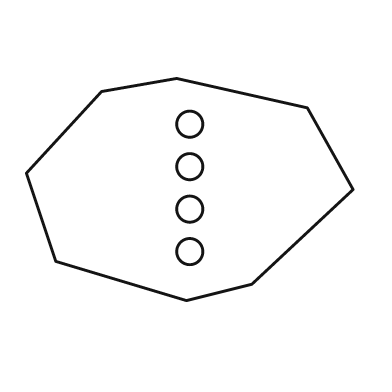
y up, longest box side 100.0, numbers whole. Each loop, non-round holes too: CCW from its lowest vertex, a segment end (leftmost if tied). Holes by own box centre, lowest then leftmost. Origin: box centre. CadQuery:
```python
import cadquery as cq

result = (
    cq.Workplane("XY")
    .moveTo(-1.0, -34.0)
    .lineTo(19.0, -29.0)
    .lineTo(50.0, 0.0)
    .lineTo(36.0, 25.0)
    .lineTo(-4.0, 34.0)
    .lineTo(-27.0, 30.0)
    .lineTo(-50.0, 5.0)
    .lineTo(-41.0, -22.0)
    .close()
    .moveTo(0.0, -19.0)
    .circle(4.0)
    .moveTo(0.0, -6.0)
    .circle(4.0)
    .moveTo(0.0, 7.0)
    .circle(4.0)
    .moveTo(0.0, 20.0)
    .circle(4.0)
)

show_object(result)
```